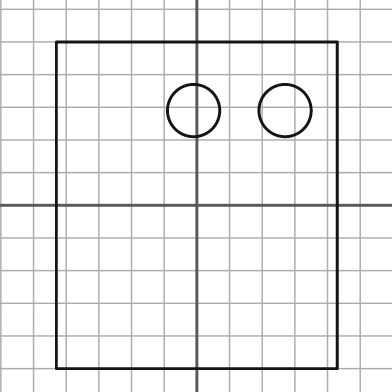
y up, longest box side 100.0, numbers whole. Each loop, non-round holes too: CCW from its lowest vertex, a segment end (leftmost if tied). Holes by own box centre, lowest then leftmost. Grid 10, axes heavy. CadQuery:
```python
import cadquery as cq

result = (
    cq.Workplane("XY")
    .moveTo(-43.0, -50.0)
    .lineTo(43.0, -50.0)
    .lineTo(43.0, 50.0)
    .lineTo(-43.0, 50.0)
    .close()
    .moveTo(-1.0, 29.0)
    .circle(8.0)
    .moveTo(27.0, 29.0)
    .circle(8.0)
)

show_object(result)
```